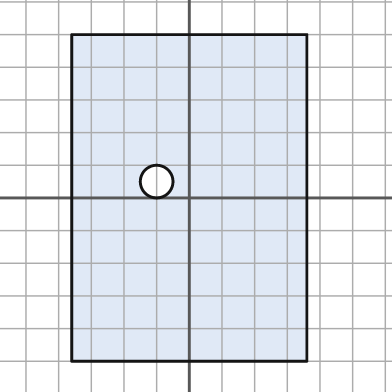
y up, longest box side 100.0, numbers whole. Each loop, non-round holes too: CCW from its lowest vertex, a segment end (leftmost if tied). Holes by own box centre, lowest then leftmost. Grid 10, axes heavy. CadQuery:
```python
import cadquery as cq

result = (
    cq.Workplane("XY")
    .moveTo(-36.0, -50.0)
    .lineTo(36.0, -50.0)
    .lineTo(36.0, 50.0)
    .lineTo(-36.0, 50.0)
    .close()
    .moveTo(-10.0, 5.0)
    .circle(5.0)
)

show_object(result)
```